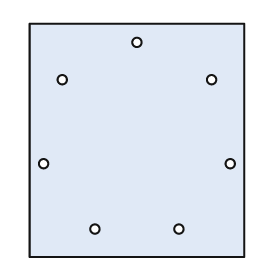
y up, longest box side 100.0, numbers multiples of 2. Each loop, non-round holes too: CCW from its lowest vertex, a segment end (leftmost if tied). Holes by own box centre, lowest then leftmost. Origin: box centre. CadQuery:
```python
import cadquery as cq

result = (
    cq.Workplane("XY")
    .moveTo(-46.0, -50.0)
    .lineTo(46.0, -50.0)
    .lineTo(46.0, 50.0)
    .lineTo(-46.0, 50.0)
    .close()
    .moveTo(-18.0, -38.0)
    .circle(2.0)
    .moveTo(18.0, -38.0)
    .circle(2.0)
    .moveTo(-40.0, -10.0)
    .circle(2.0)
    .moveTo(40.0, -10.0)
    .circle(2.0)
    .moveTo(-32.0, 26.0)
    .circle(2.0)
    .moveTo(32.0, 26.0)
    .circle(2.0)
    .moveTo(0.0, 42.0)
    .circle(2.0)
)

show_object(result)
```